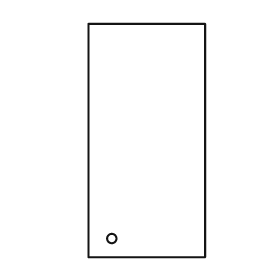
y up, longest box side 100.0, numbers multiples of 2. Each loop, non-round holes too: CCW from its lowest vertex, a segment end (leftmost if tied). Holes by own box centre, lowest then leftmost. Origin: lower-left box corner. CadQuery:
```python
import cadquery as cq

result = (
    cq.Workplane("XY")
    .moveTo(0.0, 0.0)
    .lineTo(50.0, 0.0)
    .lineTo(50.0, 100.0)
    .lineTo(0.0, 100.0)
    .close()
    .moveTo(10.0, 8.0)
    .circle(2.0)
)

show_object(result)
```